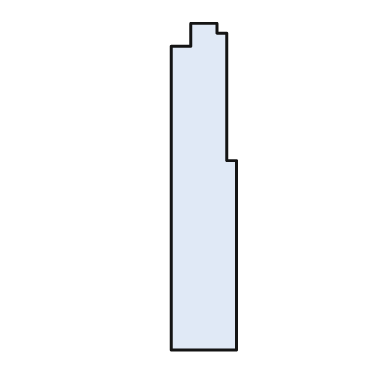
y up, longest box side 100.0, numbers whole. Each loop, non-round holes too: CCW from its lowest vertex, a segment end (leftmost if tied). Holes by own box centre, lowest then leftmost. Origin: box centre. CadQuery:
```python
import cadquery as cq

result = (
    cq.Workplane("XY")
    .moveTo(-10.0, -50.0)
    .lineTo(10.0, -50.0)
    .lineTo(10.0, 8.0)
    .lineTo(7.0, 8.0)
    .lineTo(7.0, 47.0)
    .lineTo(4.0, 47.0)
    .lineTo(4.0, 50.0)
    .lineTo(-4.0, 50.0)
    .lineTo(-4.0, 43.0)
    .lineTo(-10.0, 43.0)
    .close()
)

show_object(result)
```